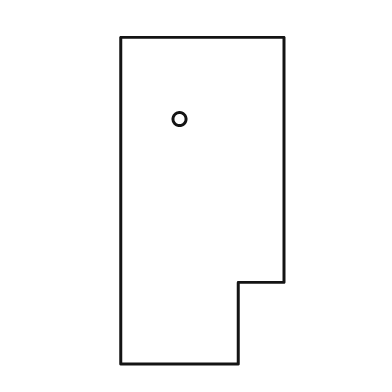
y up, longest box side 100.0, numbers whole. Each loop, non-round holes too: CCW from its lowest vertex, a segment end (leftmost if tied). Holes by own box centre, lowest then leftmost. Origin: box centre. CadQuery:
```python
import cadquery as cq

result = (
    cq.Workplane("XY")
    .moveTo(-25.0, -50.0)
    .lineTo(11.0, -50.0)
    .lineTo(11.0, -25.0)
    .lineTo(25.0, -25.0)
    .lineTo(25.0, 50.0)
    .lineTo(-25.0, 50.0)
    .close()
    .moveTo(-7.0, 25.0)
    .circle(2.0)
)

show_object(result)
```